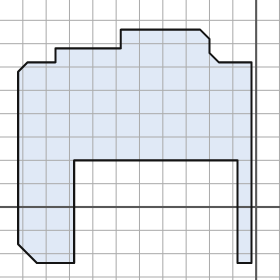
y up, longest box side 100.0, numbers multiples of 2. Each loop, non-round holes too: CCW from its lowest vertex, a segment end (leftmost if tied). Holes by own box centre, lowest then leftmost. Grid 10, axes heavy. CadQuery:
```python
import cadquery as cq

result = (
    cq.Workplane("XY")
    .moveTo(-94.0, -24.0)
    .lineTo(-78.0, -24.0)
    .lineTo(-78.0, 20.0)
    .lineTo(-8.0, 20.0)
    .lineTo(-8.0, -24.0)
    .lineTo(-2.0, -24.0)
    .lineTo(-2.0, 62.0)
    .lineTo(-16.0, 62.0)
    .lineTo(-20.0, 66.0)
    .lineTo(-20.0, 72.0)
    .lineTo(-24.0, 76.0)
    .lineTo(-58.0, 76.0)
    .lineTo(-58.0, 68.0)
    .lineTo(-86.0, 68.0)
    .lineTo(-86.0, 62.0)
    .lineTo(-98.0, 62.0)
    .lineTo(-102.0, 58.0)
    .lineTo(-102.0, -16.0)
    .close()
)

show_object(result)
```